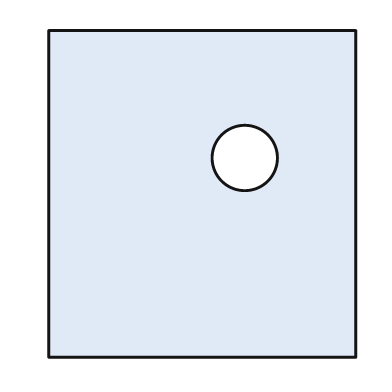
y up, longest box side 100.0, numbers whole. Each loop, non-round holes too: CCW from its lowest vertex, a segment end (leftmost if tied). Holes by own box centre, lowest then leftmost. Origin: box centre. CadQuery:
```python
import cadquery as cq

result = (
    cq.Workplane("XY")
    .moveTo(-47.0, -50.0)
    .lineTo(47.0, -50.0)
    .lineTo(47.0, 50.0)
    .lineTo(-47.0, 50.0)
    .close()
    .moveTo(13.0, 11.0)
    .circle(10.0)
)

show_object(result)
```